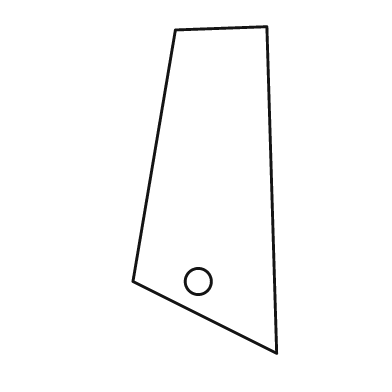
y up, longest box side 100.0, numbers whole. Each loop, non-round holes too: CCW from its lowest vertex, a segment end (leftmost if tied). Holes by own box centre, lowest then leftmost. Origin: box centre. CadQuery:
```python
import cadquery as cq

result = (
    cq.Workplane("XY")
    .moveTo(22.0, -50.0)
    .lineTo(19.0, 50.0)
    .lineTo(-9.0, 49.0)
    .lineTo(-22.0, -28.0)
    .close()
    .moveTo(-2.0, -28.0)
    .circle(4.0)
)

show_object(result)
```